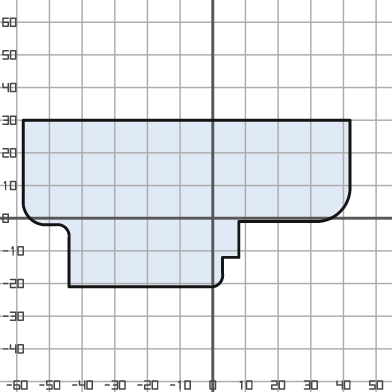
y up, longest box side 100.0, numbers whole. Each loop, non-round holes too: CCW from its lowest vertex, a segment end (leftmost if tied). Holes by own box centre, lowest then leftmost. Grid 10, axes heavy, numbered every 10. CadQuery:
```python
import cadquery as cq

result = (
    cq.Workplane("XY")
    .moveTo(-44.0, -21.0)
    .lineTo(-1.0, -21.0)
    .threePointArc((2.0, -20.0), (3.0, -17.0))
    .lineTo(3.0, -12.0)
    .lineTo(8.0, -12.0)
    .lineTo(8.0, -1.0)
    .lineTo(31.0, -1.0)
    .threePointArc((39.0, 2.0), (42.0, 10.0))
    .lineTo(42.0, 30.0)
    .lineTo(-58.0, 30.0)
    .lineTo(-58.0, 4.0)
    .threePointArc((-56.0, 0.0), (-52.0, -2.0))
    .lineTo(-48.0, -2.0)
    .threePointArc((-45.0, -3.0), (-44.0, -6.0))
    .close()
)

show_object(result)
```